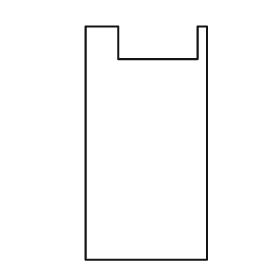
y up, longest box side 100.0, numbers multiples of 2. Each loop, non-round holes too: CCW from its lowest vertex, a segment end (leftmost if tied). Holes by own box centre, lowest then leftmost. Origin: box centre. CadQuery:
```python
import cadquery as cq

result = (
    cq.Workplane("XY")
    .moveTo(-26.0, -50.0)
    .lineTo(26.0, -50.0)
    .lineTo(26.0, 50.0)
    .lineTo(22.0, 50.0)
    .lineTo(22.0, 36.0)
    .lineTo(-12.0, 36.0)
    .lineTo(-12.0, 50.0)
    .lineTo(-26.0, 50.0)
    .close()
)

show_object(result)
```